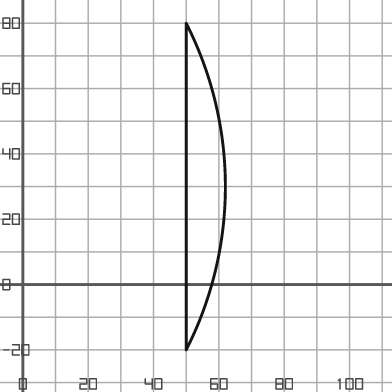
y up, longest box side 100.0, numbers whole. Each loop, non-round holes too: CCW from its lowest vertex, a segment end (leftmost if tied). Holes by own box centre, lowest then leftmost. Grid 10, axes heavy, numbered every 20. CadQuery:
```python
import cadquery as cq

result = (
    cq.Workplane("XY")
    .moveTo(50.0, -20.0)
    .threePointArc((62.0, 30.0), (50.0, 80.0))
    .close()
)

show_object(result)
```